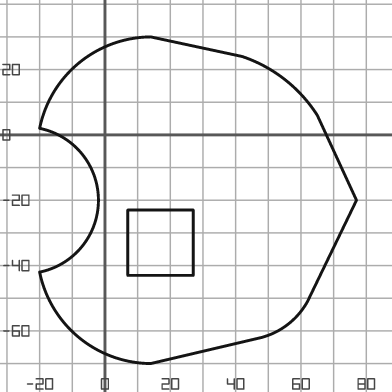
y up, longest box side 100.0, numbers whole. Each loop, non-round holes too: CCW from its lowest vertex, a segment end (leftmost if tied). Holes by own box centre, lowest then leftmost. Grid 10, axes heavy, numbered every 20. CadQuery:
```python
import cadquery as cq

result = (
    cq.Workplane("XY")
    .moveTo(14.0, -70.0)
    .lineTo(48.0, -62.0)
    .threePointArc((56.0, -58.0), (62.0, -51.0))
    .lineTo(77.0, -20.0)
    .lineTo(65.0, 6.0)
    .threePointArc((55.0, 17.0), (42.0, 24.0))
    .lineTo(14.0, 30.0)
    .threePointArc((-8.0, 22.0), (-20.0, 2.0))
    .threePointArc((-2.0, -20.0), (-20.0, -42.0))
    .threePointArc((-8.0, -62.0), (14.0, -70.0))
    .close()
    .moveTo(7.0, -43.0)
    .lineTo(27.0, -43.0)
    .lineTo(27.0, -23.0)
    .lineTo(7.0, -23.0)
    .close()
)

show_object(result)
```